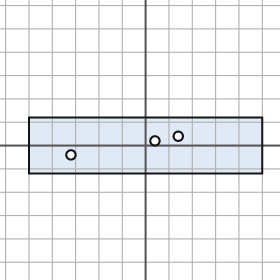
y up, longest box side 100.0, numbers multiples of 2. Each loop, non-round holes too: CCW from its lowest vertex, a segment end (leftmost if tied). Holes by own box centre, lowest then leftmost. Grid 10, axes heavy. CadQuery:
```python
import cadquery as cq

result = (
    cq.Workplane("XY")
    .moveTo(-50.0, -12.0)
    .lineTo(50.0, -12.0)
    .lineTo(50.0, 12.0)
    .lineTo(-50.0, 12.0)
    .close()
    .moveTo(-32.0, -4.0)
    .circle(2.0)
    .moveTo(4.0, 2.0)
    .circle(2.0)
    .moveTo(14.0, 4.0)
    .circle(2.0)
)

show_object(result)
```